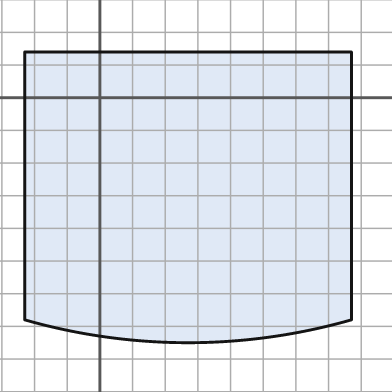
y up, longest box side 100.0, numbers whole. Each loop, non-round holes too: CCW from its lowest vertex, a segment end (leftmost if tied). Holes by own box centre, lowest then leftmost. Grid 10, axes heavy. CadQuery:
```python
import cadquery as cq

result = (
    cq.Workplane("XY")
    .moveTo(-23.0, -68.0)
    .threePointArc((27.0, -75.0), (77.0, -68.0))
    .lineTo(77.0, 14.0)
    .lineTo(-23.0, 14.0)
    .close()
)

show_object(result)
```